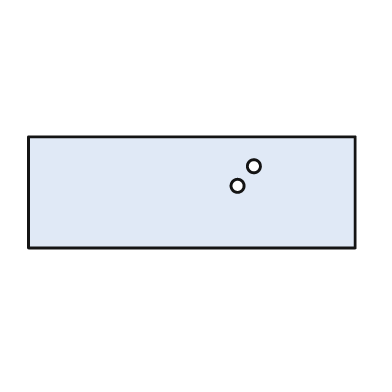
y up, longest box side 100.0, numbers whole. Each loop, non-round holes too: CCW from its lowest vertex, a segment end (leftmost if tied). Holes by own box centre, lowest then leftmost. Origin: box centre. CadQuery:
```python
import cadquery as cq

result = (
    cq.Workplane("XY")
    .moveTo(-50.0, -17.0)
    .lineTo(50.0, -17.0)
    .lineTo(50.0, 17.0)
    .lineTo(-50.0, 17.0)
    .close()
    .moveTo(14.0, 2.0)
    .circle(2.0)
    .moveTo(19.0, 8.0)
    .circle(2.0)
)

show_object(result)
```